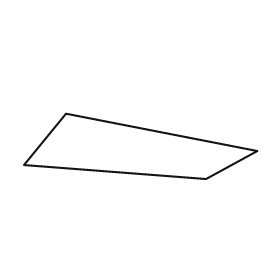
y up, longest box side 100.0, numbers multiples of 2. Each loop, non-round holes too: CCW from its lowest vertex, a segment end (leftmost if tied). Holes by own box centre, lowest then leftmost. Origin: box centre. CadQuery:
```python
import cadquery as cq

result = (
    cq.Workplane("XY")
    .moveTo(28.0, -14.0)
    .lineTo(50.0, -2.0)
    .lineTo(-32.0, 14.0)
    .lineTo(-50.0, -8.0)
    .close()
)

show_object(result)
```